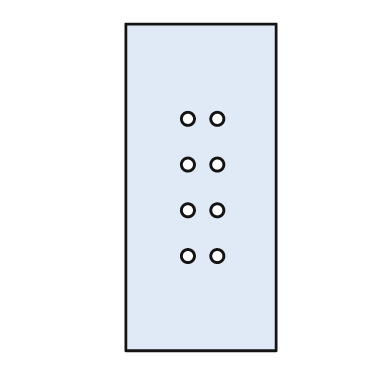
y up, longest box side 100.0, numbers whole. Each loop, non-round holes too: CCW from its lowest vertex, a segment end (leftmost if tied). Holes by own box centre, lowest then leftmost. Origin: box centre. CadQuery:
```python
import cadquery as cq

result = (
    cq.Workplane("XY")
    .moveTo(-23.0, -50.0)
    .lineTo(23.0, -50.0)
    .lineTo(23.0, 50.0)
    .lineTo(-23.0, 50.0)
    .close()
    .moveTo(-4.0, -21.0)
    .circle(2.0)
    .moveTo(5.0, -21.0)
    .circle(2.0)
    .moveTo(-4.0, -7.0)
    .circle(2.0)
    .moveTo(5.0, -7.0)
    .circle(2.0)
    .moveTo(-4.0, 7.0)
    .circle(2.0)
    .moveTo(5.0, 7.0)
    .circle(2.0)
    .moveTo(-4.0, 21.0)
    .circle(2.0)
    .moveTo(5.0, 21.0)
    .circle(2.0)
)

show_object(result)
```